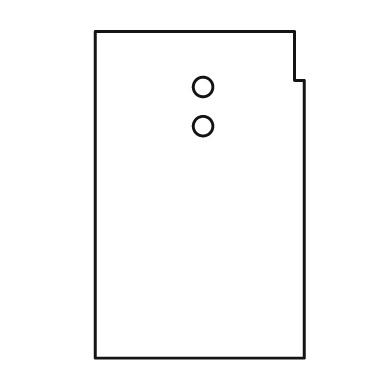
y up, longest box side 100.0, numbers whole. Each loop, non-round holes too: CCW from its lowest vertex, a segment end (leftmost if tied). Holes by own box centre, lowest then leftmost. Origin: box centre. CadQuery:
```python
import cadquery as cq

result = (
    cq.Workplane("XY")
    .moveTo(-32.0, -50.0)
    .lineTo(32.0, -50.0)
    .lineTo(32.0, 35.0)
    .lineTo(29.0, 35.0)
    .lineTo(29.0, 50.0)
    .lineTo(-32.0, 50.0)
    .close()
    .moveTo(1.0, 21.0)
    .circle(3.0)
    .moveTo(1.0, 33.0)
    .circle(3.0)
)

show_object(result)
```